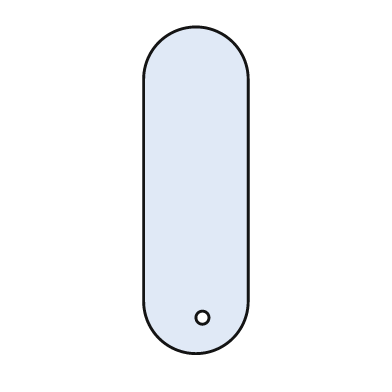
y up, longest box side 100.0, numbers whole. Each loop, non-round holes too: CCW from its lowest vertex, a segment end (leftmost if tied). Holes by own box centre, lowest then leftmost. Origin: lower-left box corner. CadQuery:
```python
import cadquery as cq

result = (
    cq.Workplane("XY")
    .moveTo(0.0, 16.0)
    .threePointArc((16.0, 0.0), (32.0, 16.0))
    .lineTo(32.0, 84.0)
    .threePointArc((16.0, 100.0), (0.0, 84.0))
    .close()
    .moveTo(18.0, 11.0)
    .circle(2.0)
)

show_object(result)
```